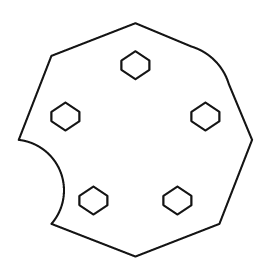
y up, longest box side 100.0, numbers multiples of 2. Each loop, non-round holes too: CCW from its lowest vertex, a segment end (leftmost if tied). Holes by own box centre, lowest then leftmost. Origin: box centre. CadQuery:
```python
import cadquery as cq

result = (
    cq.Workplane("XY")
    .moveTo(0.0, -50.0)
    .lineTo(36.0, -36.0)
    .lineTo(50.0, 0.0)
    .lineTo(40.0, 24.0)
    .threePointArc((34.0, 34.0), (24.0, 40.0))
    .lineTo(0.0, 50.0)
    .lineTo(-36.0, 36.0)
    .lineTo(-50.0, 0.0)
    .threePointArc((-32.0, -14.0), (-36.0, -36.0))
    .close()
    .moveTo(-18.0, -32.0)
    .lineTo(-12.0, -28.0)
    .lineTo(-12.0, -24.0)
    .lineTo(-18.0, -20.0)
    .lineTo(-24.0, -24.0)
    .lineTo(-24.0, -28.0)
    .close()
    .moveTo(18.0, -32.0)
    .lineTo(24.0, -28.0)
    .lineTo(24.0, -24.0)
    .lineTo(18.0, -20.0)
    .lineTo(12.0, -24.0)
    .lineTo(12.0, -28.0)
    .close()
    .moveTo(-30.0, 4.0)
    .lineTo(-24.0, 8.0)
    .lineTo(-24.0, 12.0)
    .lineTo(-30.0, 16.0)
    .lineTo(-36.0, 12.0)
    .lineTo(-36.0, 8.0)
    .close()
    .moveTo(30.0, 4.0)
    .lineTo(36.0, 8.0)
    .lineTo(36.0, 12.0)
    .lineTo(30.0, 16.0)
    .lineTo(24.0, 12.0)
    .lineTo(24.0, 8.0)
    .close()
    .moveTo(0.0, 26.0)
    .lineTo(6.0, 30.0)
    .lineTo(6.0, 34.0)
    .lineTo(0.0, 38.0)
    .lineTo(-6.0, 34.0)
    .lineTo(-6.0, 30.0)
    .close()
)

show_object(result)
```